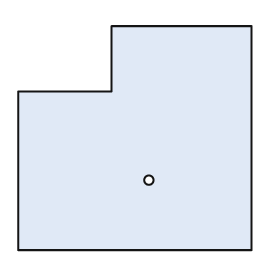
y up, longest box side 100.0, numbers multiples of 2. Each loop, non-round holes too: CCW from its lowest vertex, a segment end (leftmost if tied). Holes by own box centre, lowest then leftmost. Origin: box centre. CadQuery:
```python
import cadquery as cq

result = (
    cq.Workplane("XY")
    .moveTo(-50.0, -48.0)
    .lineTo(50.0, -48.0)
    .lineTo(50.0, 48.0)
    .lineTo(-10.0, 48.0)
    .lineTo(-10.0, 20.0)
    .lineTo(-50.0, 20.0)
    .close()
    .moveTo(6.0, -18.0)
    .circle(2.0)
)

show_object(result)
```